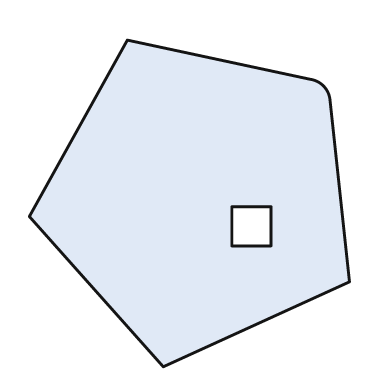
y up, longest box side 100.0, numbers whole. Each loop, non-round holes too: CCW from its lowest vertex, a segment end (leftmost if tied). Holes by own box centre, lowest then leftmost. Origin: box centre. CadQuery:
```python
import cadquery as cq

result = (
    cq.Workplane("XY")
    .moveTo(-8.0, -50.0)
    .lineTo(49.0, -24.0)
    .lineTo(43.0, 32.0)
    .threePointArc((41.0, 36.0), (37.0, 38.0))
    .lineTo(-19.0, 50.0)
    .lineTo(-49.0, -4.0)
    .close()
    .moveTo(13.0, -13.0)
    .lineTo(25.0, -13.0)
    .lineTo(25.0, -1.0)
    .lineTo(13.0, -1.0)
    .close()
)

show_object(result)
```